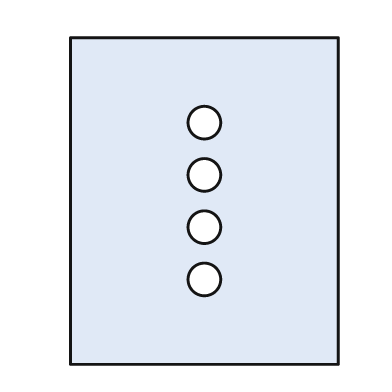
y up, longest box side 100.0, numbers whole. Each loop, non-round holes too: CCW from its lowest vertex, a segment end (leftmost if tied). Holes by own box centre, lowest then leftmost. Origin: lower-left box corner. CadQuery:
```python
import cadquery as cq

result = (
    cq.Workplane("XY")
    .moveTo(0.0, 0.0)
    .lineTo(82.0, 0.0)
    .lineTo(82.0, 100.0)
    .lineTo(0.0, 100.0)
    .close()
    .moveTo(41.0, 26.0)
    .circle(5.0)
    .moveTo(41.0, 42.0)
    .circle(5.0)
    .moveTo(41.0, 58.0)
    .circle(5.0)
    .moveTo(41.0, 74.0)
    .circle(5.0)
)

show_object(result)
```